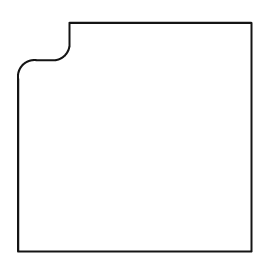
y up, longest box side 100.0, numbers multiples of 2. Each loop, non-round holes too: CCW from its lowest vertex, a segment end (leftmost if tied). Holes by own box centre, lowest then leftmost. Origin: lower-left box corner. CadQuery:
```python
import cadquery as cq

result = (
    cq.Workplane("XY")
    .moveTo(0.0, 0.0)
    .lineTo(100.0, 0.0)
    .lineTo(100.0, 98.0)
    .lineTo(22.0, 98.0)
    .lineTo(22.0, 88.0)
    .threePointArc((20.0, 84.0), (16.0, 82.0))
    .lineTo(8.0, 82.0)
    .threePointArc((2.0, 80.0), (0.0, 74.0))
    .close()
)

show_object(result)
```